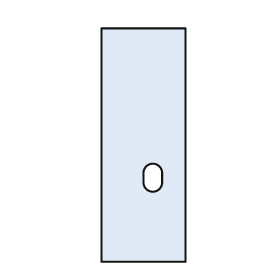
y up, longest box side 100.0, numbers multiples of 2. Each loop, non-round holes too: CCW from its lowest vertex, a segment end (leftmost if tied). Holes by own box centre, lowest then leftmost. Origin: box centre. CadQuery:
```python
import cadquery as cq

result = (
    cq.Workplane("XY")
    .moveTo(-18.0, -50.0)
    .lineTo(18.0, -50.0)
    .lineTo(18.0, 50.0)
    .lineTo(-18.0, 50.0)
    .close()
    .moveTo(0.0, -16.0)
    .threePointArc((4.0, -20.0), (8.0, -16.0))
    .lineTo(8.0, -12.0)
    .threePointArc((4.0, -8.0), (0.0, -12.0))
    .close()
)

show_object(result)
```